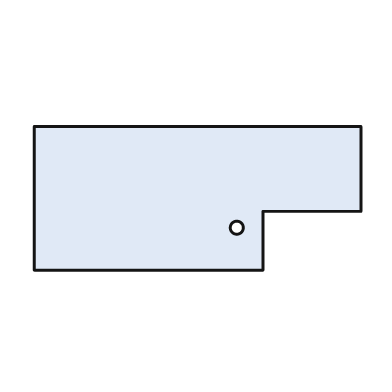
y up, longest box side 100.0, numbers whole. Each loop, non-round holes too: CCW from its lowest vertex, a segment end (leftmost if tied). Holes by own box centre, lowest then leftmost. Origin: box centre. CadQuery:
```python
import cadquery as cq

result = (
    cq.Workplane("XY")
    .moveTo(-50.0, -22.0)
    .lineTo(20.0, -22.0)
    .lineTo(20.0, -4.0)
    .lineTo(50.0, -4.0)
    .lineTo(50.0, 22.0)
    .lineTo(-50.0, 22.0)
    .close()
    .moveTo(12.0, -9.0)
    .circle(2.0)
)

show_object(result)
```